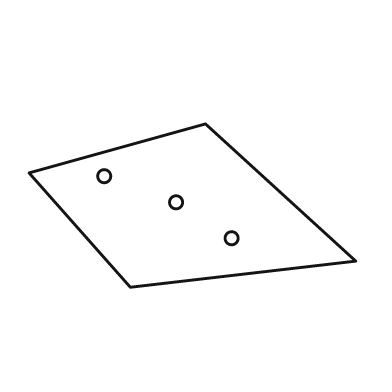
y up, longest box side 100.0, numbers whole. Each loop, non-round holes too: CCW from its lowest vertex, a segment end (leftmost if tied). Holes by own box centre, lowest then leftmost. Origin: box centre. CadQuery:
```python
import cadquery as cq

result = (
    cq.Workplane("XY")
    .moveTo(-19.0, -25.0)
    .lineTo(50.0, -17.0)
    .lineTo(4.0, 25.0)
    .lineTo(-50.0, 10.0)
    .close()
    .moveTo(12.0, -10.0)
    .circle(2.0)
    .moveTo(-5.0, 1.0)
    .circle(2.0)
    .moveTo(-27.0, 9.0)
    .circle(2.0)
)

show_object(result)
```